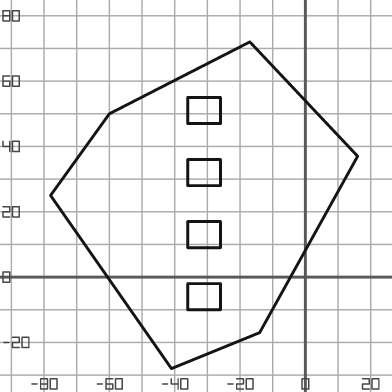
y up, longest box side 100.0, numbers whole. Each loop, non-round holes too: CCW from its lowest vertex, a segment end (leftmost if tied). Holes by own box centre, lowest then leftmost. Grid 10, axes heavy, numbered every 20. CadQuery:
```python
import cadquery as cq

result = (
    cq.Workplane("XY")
    .moveTo(-41.0, -28.0)
    .lineTo(-14.0, -17.0)
    .lineTo(16.0, 37.0)
    .lineTo(-17.0, 72.0)
    .lineTo(-60.0, 50.0)
    .lineTo(-78.0, 25.0)
    .close()
    .moveTo(-36.0, -10.0)
    .lineTo(-26.0, -10.0)
    .lineTo(-26.0, -2.0)
    .lineTo(-36.0, -2.0)
    .close()
    .moveTo(-36.0, 9.0)
    .lineTo(-26.0, 9.0)
    .lineTo(-26.0, 17.0)
    .lineTo(-36.0, 17.0)
    .close()
    .moveTo(-36.0, 28.0)
    .lineTo(-26.0, 28.0)
    .lineTo(-26.0, 36.0)
    .lineTo(-36.0, 36.0)
    .close()
    .moveTo(-36.0, 47.0)
    .lineTo(-26.0, 47.0)
    .lineTo(-26.0, 55.0)
    .lineTo(-36.0, 55.0)
    .close()
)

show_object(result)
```